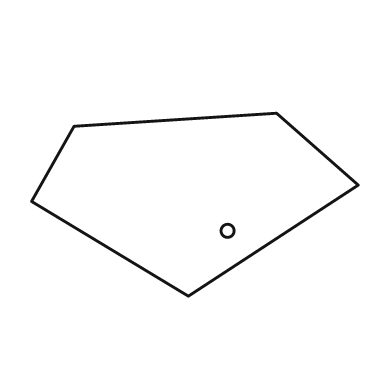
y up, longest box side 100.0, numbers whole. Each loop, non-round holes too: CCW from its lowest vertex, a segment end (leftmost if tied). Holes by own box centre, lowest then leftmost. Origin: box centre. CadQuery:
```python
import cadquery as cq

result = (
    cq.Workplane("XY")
    .moveTo(-2.0, -28.0)
    .lineTo(50.0, 6.0)
    .lineTo(25.0, 28.0)
    .lineTo(-37.0, 24.0)
    .lineTo(-50.0, 1.0)
    .close()
    .moveTo(10.0, -8.0)
    .circle(2.0)
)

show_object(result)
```